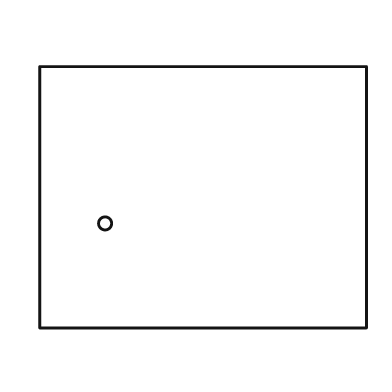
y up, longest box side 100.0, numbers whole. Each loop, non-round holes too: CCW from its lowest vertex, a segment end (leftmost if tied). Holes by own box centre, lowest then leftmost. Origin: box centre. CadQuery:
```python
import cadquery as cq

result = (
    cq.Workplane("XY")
    .moveTo(-50.0, -40.0)
    .lineTo(50.0, -40.0)
    .lineTo(50.0, 40.0)
    .lineTo(-50.0, 40.0)
    .close()
    .moveTo(-30.0, -8.0)
    .circle(2.0)
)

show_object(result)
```